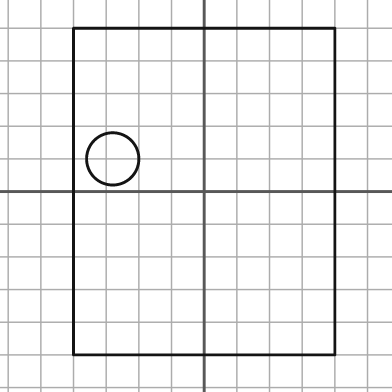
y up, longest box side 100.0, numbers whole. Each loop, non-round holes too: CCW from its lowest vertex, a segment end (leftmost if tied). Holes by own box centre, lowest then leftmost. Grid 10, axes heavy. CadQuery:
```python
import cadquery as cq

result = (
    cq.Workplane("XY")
    .moveTo(-40.0, -50.0)
    .lineTo(40.0, -50.0)
    .lineTo(40.0, 50.0)
    .lineTo(-40.0, 50.0)
    .close()
    .moveTo(-28.0, 10.0)
    .circle(8.0)
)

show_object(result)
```